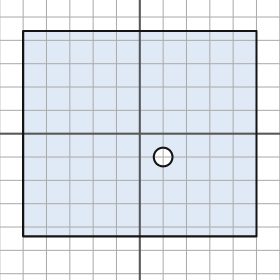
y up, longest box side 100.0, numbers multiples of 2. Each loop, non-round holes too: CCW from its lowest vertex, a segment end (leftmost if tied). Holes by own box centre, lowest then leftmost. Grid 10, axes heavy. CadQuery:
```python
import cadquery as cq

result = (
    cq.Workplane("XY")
    .moveTo(-50.0, -44.0)
    .lineTo(50.0, -44.0)
    .lineTo(50.0, 44.0)
    .lineTo(-50.0, 44.0)
    .close()
    .moveTo(10.0, -10.0)
    .circle(4.0)
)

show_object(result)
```